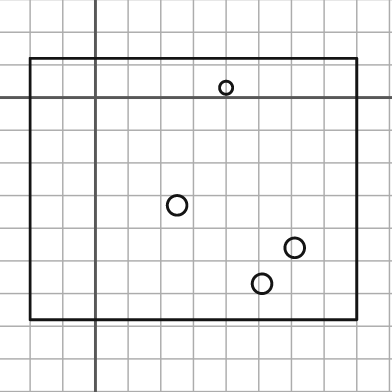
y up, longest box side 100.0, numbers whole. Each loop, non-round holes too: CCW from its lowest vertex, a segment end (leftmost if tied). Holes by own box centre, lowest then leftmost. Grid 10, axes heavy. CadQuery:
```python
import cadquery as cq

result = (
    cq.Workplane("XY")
    .moveTo(-20.0, -68.0)
    .lineTo(80.0, -68.0)
    .lineTo(80.0, 12.0)
    .lineTo(-20.0, 12.0)
    .close()
    .moveTo(51.0, -57.0)
    .circle(3.0)
    .moveTo(61.0, -46.0)
    .circle(3.0)
    .moveTo(25.0, -33.0)
    .circle(3.0)
    .moveTo(40.0, 3.0)
    .circle(2.0)
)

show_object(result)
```